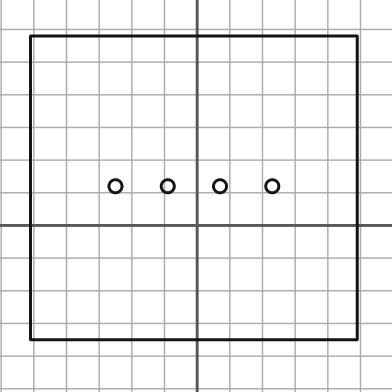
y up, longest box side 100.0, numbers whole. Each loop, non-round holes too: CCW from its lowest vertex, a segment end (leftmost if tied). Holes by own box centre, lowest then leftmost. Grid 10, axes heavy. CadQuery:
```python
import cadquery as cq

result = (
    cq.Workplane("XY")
    .moveTo(-51.0, -35.0)
    .lineTo(49.0, -35.0)
    .lineTo(49.0, 58.0)
    .lineTo(-51.0, 58.0)
    .close()
    .moveTo(-25.0, 12.0)
    .circle(2.0)
    .moveTo(-9.0, 12.0)
    .circle(2.0)
    .moveTo(7.0, 12.0)
    .circle(2.0)
    .moveTo(23.0, 12.0)
    .circle(2.0)
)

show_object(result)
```